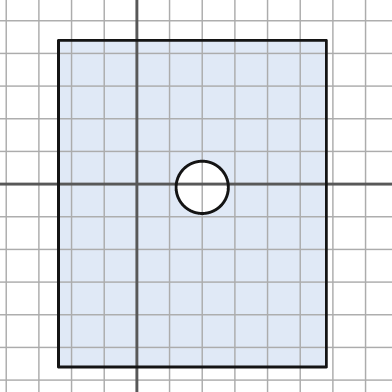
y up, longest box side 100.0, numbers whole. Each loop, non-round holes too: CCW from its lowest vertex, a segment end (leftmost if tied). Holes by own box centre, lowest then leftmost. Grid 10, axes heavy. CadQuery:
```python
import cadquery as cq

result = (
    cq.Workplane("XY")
    .moveTo(-24.0, -56.0)
    .lineTo(58.0, -56.0)
    .lineTo(58.0, 44.0)
    .lineTo(-24.0, 44.0)
    .close()
    .moveTo(20.0, -1.0)
    .circle(8.0)
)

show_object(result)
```